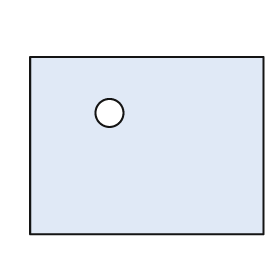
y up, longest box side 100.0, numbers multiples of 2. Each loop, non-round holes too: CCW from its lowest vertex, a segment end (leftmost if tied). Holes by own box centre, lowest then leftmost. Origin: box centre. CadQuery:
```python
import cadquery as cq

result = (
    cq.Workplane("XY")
    .moveTo(-50.0, -38.0)
    .lineTo(50.0, -38.0)
    .lineTo(50.0, 38.0)
    .lineTo(-50.0, 38.0)
    .close()
    .moveTo(-16.0, 14.0)
    .circle(6.0)
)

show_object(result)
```